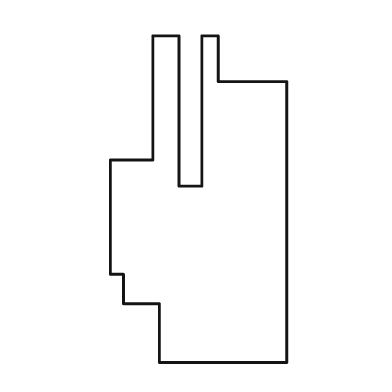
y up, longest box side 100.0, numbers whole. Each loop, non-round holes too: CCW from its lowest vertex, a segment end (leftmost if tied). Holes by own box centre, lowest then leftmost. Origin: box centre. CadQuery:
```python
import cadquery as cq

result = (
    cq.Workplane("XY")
    .moveTo(-12.0, -50.0)
    .lineTo(27.0, -50.0)
    .lineTo(27.0, 36.0)
    .lineTo(6.0, 36.0)
    .lineTo(6.0, 50.0)
    .lineTo(1.0, 50.0)
    .lineTo(1.0, 4.0)
    .lineTo(-6.0, 4.0)
    .lineTo(-6.0, 50.0)
    .lineTo(-14.0, 50.0)
    .lineTo(-14.0, 12.0)
    .lineTo(-27.0, 12.0)
    .lineTo(-27.0, -23.0)
    .lineTo(-23.0, -23.0)
    .lineTo(-23.0, -32.0)
    .lineTo(-12.0, -32.0)
    .close()
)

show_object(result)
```